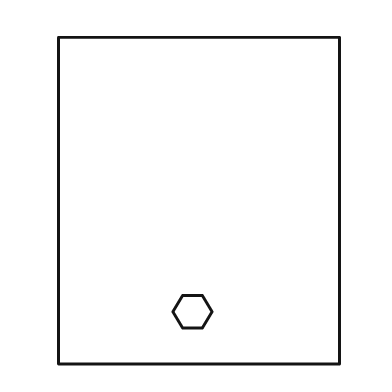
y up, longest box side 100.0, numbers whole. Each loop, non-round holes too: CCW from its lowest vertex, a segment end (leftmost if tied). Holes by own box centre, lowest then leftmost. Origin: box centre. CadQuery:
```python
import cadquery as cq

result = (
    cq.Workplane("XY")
    .moveTo(-43.0, -50.0)
    .lineTo(43.0, -50.0)
    .lineTo(43.0, 50.0)
    .lineTo(-43.0, 50.0)
    .close()
    .moveTo(-5.0, -39.0)
    .lineTo(1.0, -39.0)
    .lineTo(4.0, -34.0)
    .lineTo(1.0, -29.0)
    .lineTo(-5.0, -29.0)
    .lineTo(-8.0, -34.0)
    .close()
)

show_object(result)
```